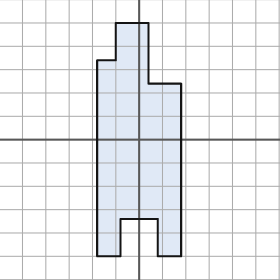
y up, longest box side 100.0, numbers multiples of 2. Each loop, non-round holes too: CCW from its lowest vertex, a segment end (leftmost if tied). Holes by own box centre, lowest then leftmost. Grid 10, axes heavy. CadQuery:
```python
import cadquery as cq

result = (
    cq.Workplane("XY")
    .moveTo(-18.0, -50.0)
    .lineTo(-8.0, -50.0)
    .lineTo(-8.0, -34.0)
    .lineTo(8.0, -34.0)
    .lineTo(8.0, -50.0)
    .lineTo(18.0, -50.0)
    .lineTo(18.0, 24.0)
    .lineTo(4.0, 24.0)
    .lineTo(4.0, 50.0)
    .lineTo(-10.0, 50.0)
    .lineTo(-10.0, 34.0)
    .lineTo(-18.0, 34.0)
    .close()
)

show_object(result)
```